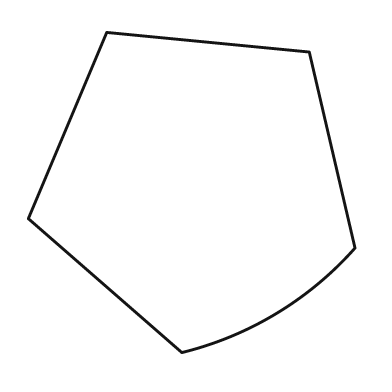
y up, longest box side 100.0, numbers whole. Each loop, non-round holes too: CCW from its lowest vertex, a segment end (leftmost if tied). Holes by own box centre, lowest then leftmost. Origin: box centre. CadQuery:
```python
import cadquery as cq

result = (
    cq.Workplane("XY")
    .moveTo(-3.0, -49.0)
    .threePointArc((26.0, -37.0), (50.0, -17.0))
    .lineTo(36.0, 43.0)
    .lineTo(-26.0, 49.0)
    .lineTo(-50.0, -8.0)
    .close()
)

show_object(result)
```